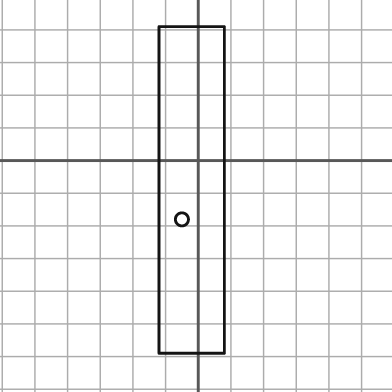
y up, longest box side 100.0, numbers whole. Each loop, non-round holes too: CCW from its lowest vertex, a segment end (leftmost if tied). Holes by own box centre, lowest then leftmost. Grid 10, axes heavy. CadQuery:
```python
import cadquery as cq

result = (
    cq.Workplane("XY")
    .moveTo(-12.0, -59.0)
    .lineTo(8.0, -59.0)
    .lineTo(8.0, 41.0)
    .lineTo(-12.0, 41.0)
    .close()
    .moveTo(-5.0, -18.0)
    .circle(2.0)
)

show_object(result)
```